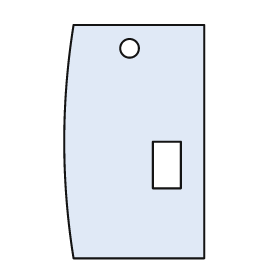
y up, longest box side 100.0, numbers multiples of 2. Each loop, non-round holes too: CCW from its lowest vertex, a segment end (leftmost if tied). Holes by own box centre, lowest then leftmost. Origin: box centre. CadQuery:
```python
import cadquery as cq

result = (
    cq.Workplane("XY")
    .moveTo(-26.0, -50.0)
    .lineTo(30.0, -50.0)
    .lineTo(30.0, 50.0)
    .lineTo(-26.0, 50.0)
    .threePointArc((-30.0, 0.0), (-26.0, -50.0))
    .close()
    .moveTo(8.0, -20.0)
    .lineTo(20.0, -20.0)
    .lineTo(20.0, 0.0)
    .lineTo(8.0, 0.0)
    .close()
    .moveTo(-2.0, 40.0)
    .circle(4.0)
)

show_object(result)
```